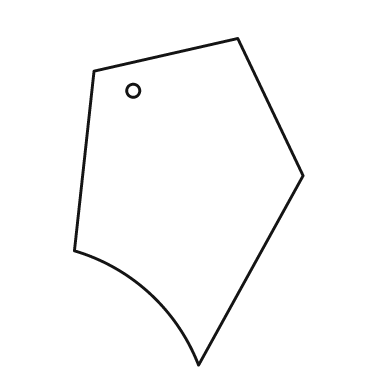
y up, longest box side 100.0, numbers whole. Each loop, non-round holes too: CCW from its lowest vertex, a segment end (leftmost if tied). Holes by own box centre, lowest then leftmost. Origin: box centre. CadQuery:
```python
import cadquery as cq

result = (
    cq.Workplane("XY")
    .moveTo(3.0, -50.0)
    .lineTo(35.0, 8.0)
    .lineTo(15.0, 50.0)
    .lineTo(-29.0, 40.0)
    .lineTo(-35.0, -15.0)
    .threePointArc((-12.0, -28.0), (3.0, -50.0))
    .close()
    .moveTo(-17.0, 34.0)
    .circle(2.0)
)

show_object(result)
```